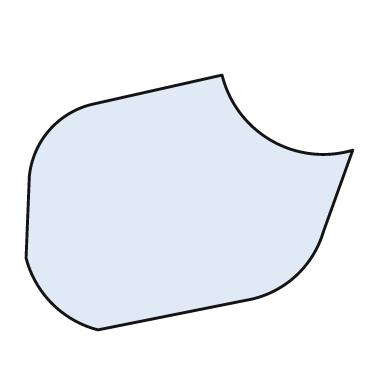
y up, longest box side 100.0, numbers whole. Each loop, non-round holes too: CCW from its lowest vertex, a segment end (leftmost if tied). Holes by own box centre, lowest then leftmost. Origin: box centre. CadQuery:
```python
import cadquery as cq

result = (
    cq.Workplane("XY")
    .moveTo(-28.0, -39.0)
    .lineTo(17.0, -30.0)
    .threePointArc((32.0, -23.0), (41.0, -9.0))
    .lineTo(50.0, 16.0)
    .threePointArc((25.0, 19.0), (10.0, 39.0))
    .lineTo(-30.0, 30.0)
    .threePointArc((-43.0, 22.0), (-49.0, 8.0))
    .lineTo(-50.0, -17.0)
    .threePointArc((-42.0, -31.0), (-28.0, -39.0))
    .close()
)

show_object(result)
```